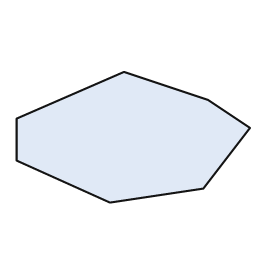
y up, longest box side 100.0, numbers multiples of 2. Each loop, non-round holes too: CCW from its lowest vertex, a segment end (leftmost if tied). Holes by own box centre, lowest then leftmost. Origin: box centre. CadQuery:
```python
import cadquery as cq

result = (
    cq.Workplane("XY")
    .moveTo(-10.0, -28.0)
    .lineTo(30.0, -22.0)
    .lineTo(50.0, 4.0)
    .lineTo(32.0, 16.0)
    .lineTo(-4.0, 28.0)
    .lineTo(-50.0, 8.0)
    .lineTo(-50.0, -10.0)
    .close()
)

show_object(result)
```